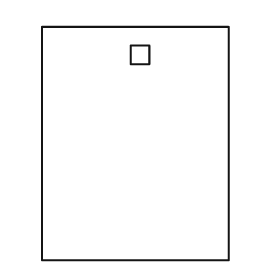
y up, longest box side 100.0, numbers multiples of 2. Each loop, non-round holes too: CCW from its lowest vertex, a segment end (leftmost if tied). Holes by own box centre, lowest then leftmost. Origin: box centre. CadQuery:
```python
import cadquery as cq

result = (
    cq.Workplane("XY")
    .moveTo(-40.0, -50.0)
    .lineTo(40.0, -50.0)
    .lineTo(40.0, 50.0)
    .lineTo(-40.0, 50.0)
    .close()
    .moveTo(-2.0, 34.0)
    .lineTo(6.0, 34.0)
    .lineTo(6.0, 42.0)
    .lineTo(-2.0, 42.0)
    .close()
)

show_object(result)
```